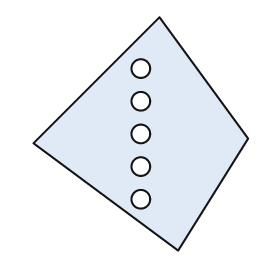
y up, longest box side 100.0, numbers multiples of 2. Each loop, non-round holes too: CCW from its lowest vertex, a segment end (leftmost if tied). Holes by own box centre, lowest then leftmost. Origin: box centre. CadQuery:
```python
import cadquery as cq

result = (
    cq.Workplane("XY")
    .moveTo(16.0, -50.0)
    .lineTo(46.0, -2.0)
    .lineTo(8.0, 50.0)
    .lineTo(-46.0, -4.0)
    .close()
    .moveTo(0.0, -28.0)
    .circle(4.0)
    .moveTo(0.0, -14.0)
    .circle(4.0)
    .moveTo(0.0, 0.0)
    .circle(4.0)
    .moveTo(0.0, 14.0)
    .circle(4.0)
    .moveTo(0.0, 28.0)
    .circle(4.0)
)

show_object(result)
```